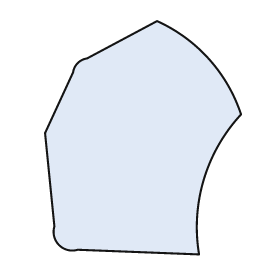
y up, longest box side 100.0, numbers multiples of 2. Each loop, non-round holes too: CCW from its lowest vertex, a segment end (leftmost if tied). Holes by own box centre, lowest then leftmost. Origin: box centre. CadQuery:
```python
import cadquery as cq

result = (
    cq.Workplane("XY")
    .moveTo(24.0, -50.0)
    .threePointArc((26.0, -18.0), (42.0, 10.0))
    .threePointArc((28.0, 34.0), (6.0, 50.0))
    .lineTo(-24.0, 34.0)
    .threePointArc((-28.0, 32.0), (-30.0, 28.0))
    .lineTo(-42.0, 2.0)
    .lineTo(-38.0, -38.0)
    .threePointArc((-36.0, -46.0), (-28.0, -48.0))
    .close()
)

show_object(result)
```